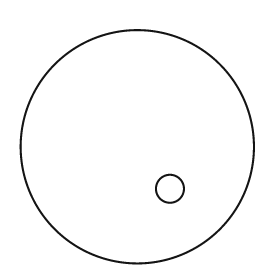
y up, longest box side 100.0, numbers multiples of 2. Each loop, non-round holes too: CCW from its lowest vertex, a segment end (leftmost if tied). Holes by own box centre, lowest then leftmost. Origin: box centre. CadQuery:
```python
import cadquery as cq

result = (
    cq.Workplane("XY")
    .moveTo(0.0, 0.0)
    .circle(50.0)
    .moveTo(14.0, -18.0)
    .circle(6.0)
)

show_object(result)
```